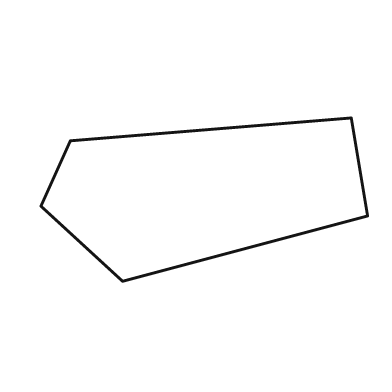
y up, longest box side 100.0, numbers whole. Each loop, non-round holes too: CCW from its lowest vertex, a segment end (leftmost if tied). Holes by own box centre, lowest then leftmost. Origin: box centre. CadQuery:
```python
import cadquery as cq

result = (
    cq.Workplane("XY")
    .moveTo(-25.0, -25.0)
    .lineTo(50.0, -5.0)
    .lineTo(45.0, 25.0)
    .lineTo(-41.0, 18.0)
    .lineTo(-50.0, -2.0)
    .close()
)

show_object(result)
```